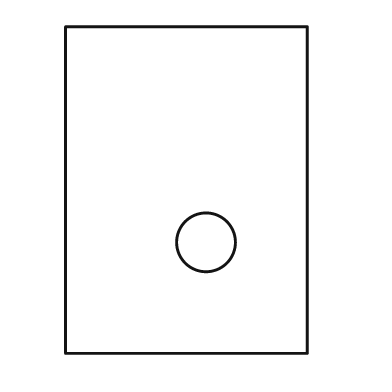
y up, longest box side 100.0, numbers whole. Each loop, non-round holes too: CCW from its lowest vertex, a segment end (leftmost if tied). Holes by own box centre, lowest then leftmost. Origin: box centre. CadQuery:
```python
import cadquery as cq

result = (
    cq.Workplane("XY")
    .moveTo(-37.0, -50.0)
    .lineTo(37.0, -50.0)
    .lineTo(37.0, 50.0)
    .lineTo(-37.0, 50.0)
    .close()
    .moveTo(6.0, -16.0)
    .circle(9.0)
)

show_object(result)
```